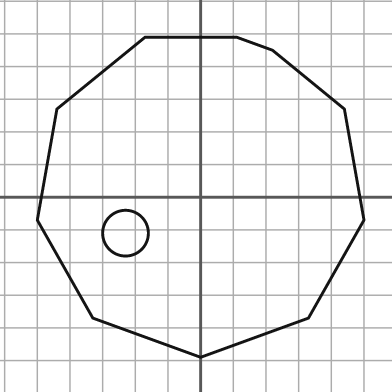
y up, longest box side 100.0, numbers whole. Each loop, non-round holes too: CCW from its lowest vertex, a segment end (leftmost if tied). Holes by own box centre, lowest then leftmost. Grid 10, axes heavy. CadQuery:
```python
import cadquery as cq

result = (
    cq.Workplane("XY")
    .moveTo(0.0, -49.0)
    .lineTo(33.0, -37.0)
    .lineTo(50.0, -7.0)
    .lineTo(44.0, 27.0)
    .lineTo(22.0, 45.0)
    .lineTo(11.0, 49.0)
    .lineTo(-17.0, 49.0)
    .lineTo(-44.0, 27.0)
    .lineTo(-50.0, -7.0)
    .lineTo(-33.0, -37.0)
    .close()
    .moveTo(-23.0, -11.0)
    .circle(7.0)
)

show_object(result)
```